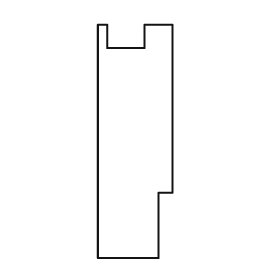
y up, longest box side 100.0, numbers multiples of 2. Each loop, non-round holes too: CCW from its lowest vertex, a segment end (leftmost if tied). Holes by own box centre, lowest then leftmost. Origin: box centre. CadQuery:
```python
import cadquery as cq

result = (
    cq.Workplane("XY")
    .moveTo(-16.0, -50.0)
    .lineTo(10.0, -50.0)
    .lineTo(10.0, -22.0)
    .lineTo(16.0, -22.0)
    .lineTo(16.0, 50.0)
    .lineTo(4.0, 50.0)
    .lineTo(4.0, 40.0)
    .lineTo(-12.0, 40.0)
    .lineTo(-12.0, 50.0)
    .lineTo(-16.0, 50.0)
    .close()
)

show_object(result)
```